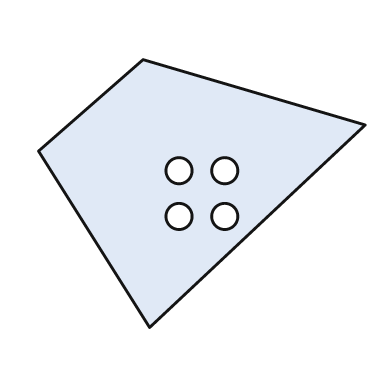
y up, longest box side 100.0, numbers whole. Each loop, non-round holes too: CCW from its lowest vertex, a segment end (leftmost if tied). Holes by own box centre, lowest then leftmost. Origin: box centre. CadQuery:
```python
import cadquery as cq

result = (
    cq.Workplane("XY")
    .moveTo(-16.0, -41.0)
    .lineTo(50.0, 21.0)
    .lineTo(-18.0, 41.0)
    .lineTo(-50.0, 13.0)
    .close()
    .moveTo(-7.0, -7.0)
    .circle(4.0)
    .moveTo(7.0, -7.0)
    .circle(4.0)
    .moveTo(-7.0, 7.0)
    .circle(4.0)
    .moveTo(7.0, 7.0)
    .circle(4.0)
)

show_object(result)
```